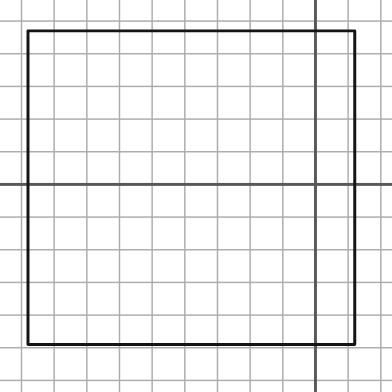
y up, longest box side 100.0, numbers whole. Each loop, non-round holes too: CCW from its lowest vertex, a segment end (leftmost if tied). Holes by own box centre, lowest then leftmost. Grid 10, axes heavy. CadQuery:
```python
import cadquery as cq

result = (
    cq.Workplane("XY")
    .moveTo(-88.0, -49.0)
    .lineTo(12.0, -49.0)
    .lineTo(12.0, 47.0)
    .lineTo(-88.0, 47.0)
    .close()
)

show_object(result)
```